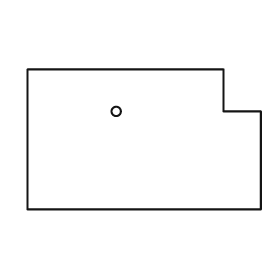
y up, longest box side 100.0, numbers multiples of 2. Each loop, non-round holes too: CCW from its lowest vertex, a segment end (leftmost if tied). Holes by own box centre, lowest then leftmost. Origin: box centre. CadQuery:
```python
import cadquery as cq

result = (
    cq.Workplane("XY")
    .moveTo(-50.0, -30.0)
    .lineTo(50.0, -30.0)
    .lineTo(50.0, 12.0)
    .lineTo(34.0, 12.0)
    .lineTo(34.0, 30.0)
    .lineTo(-50.0, 30.0)
    .close()
    .moveTo(-12.0, 12.0)
    .circle(2.0)
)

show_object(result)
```